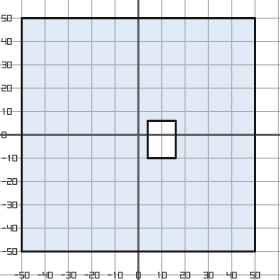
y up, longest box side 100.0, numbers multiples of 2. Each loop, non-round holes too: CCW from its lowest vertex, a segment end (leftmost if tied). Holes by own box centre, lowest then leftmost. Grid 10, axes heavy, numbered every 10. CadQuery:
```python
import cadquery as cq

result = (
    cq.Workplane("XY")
    .moveTo(-50.0, -50.0)
    .lineTo(50.0, -50.0)
    .lineTo(50.0, 50.0)
    .lineTo(-50.0, 50.0)
    .close()
    .moveTo(4.0, -10.0)
    .lineTo(16.0, -10.0)
    .lineTo(16.0, 6.0)
    .lineTo(4.0, 6.0)
    .close()
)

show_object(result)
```